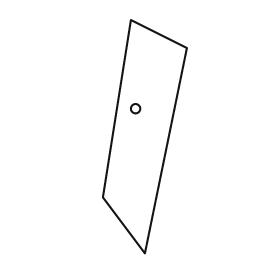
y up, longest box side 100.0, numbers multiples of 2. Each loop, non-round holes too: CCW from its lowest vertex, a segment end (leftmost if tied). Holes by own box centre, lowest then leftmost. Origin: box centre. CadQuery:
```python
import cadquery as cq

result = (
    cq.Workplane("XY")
    .moveTo(0.0, -50.0)
    .lineTo(18.0, 38.0)
    .lineTo(-6.0, 50.0)
    .lineTo(-18.0, -26.0)
    .close()
    .moveTo(-4.0, 12.0)
    .circle(2.0)
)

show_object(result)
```